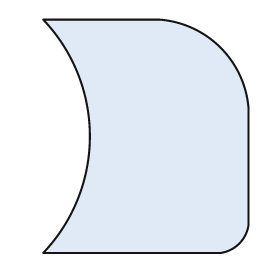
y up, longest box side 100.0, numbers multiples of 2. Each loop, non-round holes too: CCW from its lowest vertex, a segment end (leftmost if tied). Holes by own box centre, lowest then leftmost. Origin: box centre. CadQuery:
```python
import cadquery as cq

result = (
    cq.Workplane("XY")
    .moveTo(-44.0, -50.0)
    .lineTo(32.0, -50.0)
    .threePointArc((40.0, -46.0), (44.0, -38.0))
    .lineTo(44.0, 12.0)
    .threePointArc((32.0, 38.0), (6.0, 50.0))
    .lineTo(-44.0, 50.0)
    .threePointArc((-24.0, 0.0), (-44.0, -50.0))
    .close()
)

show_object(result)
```